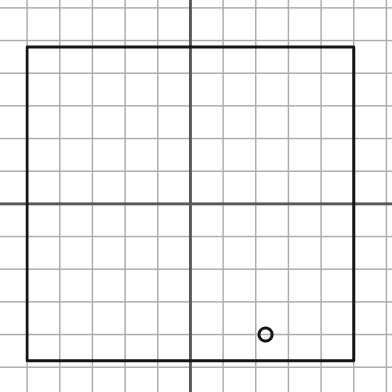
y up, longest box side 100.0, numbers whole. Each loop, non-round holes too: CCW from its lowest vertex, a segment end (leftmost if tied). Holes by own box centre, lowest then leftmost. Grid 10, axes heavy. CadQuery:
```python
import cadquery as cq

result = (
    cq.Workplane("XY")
    .moveTo(-50.0, -48.0)
    .lineTo(50.0, -48.0)
    .lineTo(50.0, 48.0)
    .lineTo(-50.0, 48.0)
    .close()
    .moveTo(23.0, -40.0)
    .circle(2.0)
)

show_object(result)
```